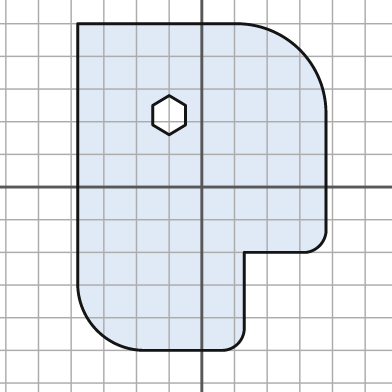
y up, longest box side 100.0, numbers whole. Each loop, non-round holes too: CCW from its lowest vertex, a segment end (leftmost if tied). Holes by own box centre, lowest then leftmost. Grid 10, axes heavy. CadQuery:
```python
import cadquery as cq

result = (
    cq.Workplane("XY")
    .moveTo(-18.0, -50.0)
    .lineTo(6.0, -50.0)
    .threePointArc((11.0, -48.0), (13.0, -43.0))
    .lineTo(13.0, -20.0)
    .lineTo(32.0, -20.0)
    .threePointArc((36.0, -18.0), (38.0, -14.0))
    .lineTo(38.0, 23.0)
    .threePointArc((30.0, 42.0), (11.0, 50.0))
    .lineTo(-38.0, 50.0)
    .lineTo(-38.0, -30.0)
    .threePointArc((-32.0, -44.0), (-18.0, -50.0))
    .close()
    .moveTo(-10.0, 16.0)
    .lineTo(-5.0, 19.0)
    .lineTo(-5.0, 25.0)
    .lineTo(-10.0, 28.0)
    .lineTo(-15.0, 25.0)
    .lineTo(-15.0, 19.0)
    .close()
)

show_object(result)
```